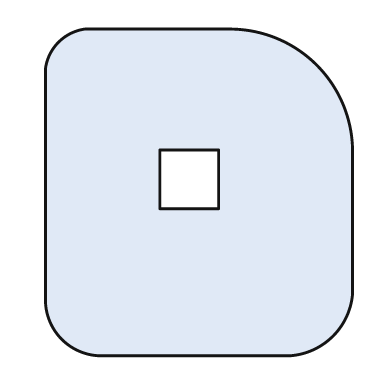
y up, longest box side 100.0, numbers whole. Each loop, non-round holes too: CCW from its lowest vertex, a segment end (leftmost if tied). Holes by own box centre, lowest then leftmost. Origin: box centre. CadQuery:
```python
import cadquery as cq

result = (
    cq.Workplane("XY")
    .moveTo(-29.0, -50.0)
    .lineTo(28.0, -50.0)
    .threePointArc((41.0, -44.0), (47.0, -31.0))
    .lineTo(47.0, 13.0)
    .threePointArc((36.0, 39.0), (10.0, 50.0))
    .lineTo(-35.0, 50.0)
    .threePointArc((-43.0, 46.0), (-47.0, 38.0))
    .lineTo(-47.0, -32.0)
    .threePointArc((-42.0, -45.0), (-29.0, -50.0))
    .close()
    .moveTo(-12.0, -5.0)
    .lineTo(6.0, -5.0)
    .lineTo(6.0, 13.0)
    .lineTo(-12.0, 13.0)
    .close()
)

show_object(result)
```